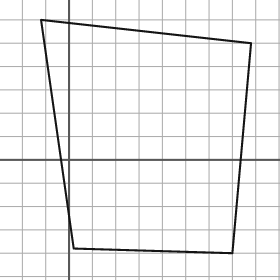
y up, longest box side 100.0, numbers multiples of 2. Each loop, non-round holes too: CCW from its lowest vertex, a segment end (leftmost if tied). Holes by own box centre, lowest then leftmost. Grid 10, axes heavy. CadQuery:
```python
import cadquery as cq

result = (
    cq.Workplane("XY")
    .moveTo(70.0, -40.0)
    .lineTo(78.0, 50.0)
    .lineTo(-12.0, 60.0)
    .lineTo(2.0, -38.0)
    .close()
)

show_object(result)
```